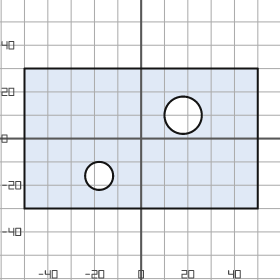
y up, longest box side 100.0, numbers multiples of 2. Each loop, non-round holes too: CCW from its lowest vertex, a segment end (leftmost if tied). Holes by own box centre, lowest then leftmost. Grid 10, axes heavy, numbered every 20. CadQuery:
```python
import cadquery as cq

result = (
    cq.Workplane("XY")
    .moveTo(-50.0, -30.0)
    .lineTo(50.0, -30.0)
    .lineTo(50.0, 30.0)
    .lineTo(-50.0, 30.0)
    .close()
    .moveTo(-18.0, -16.0)
    .circle(6.0)
    .moveTo(18.0, 10.0)
    .circle(8.0)
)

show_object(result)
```